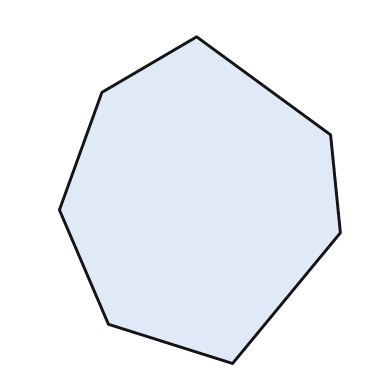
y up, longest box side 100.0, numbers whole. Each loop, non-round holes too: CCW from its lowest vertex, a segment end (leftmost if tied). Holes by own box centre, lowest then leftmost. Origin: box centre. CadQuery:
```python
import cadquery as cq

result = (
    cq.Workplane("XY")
    .moveTo(10.0, -50.0)
    .lineTo(43.0, -10.0)
    .lineTo(40.0, 20.0)
    .lineTo(-1.0, 50.0)
    .lineTo(-30.0, 33.0)
    .lineTo(-43.0, -3.0)
    .lineTo(-28.0, -38.0)
    .close()
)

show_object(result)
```